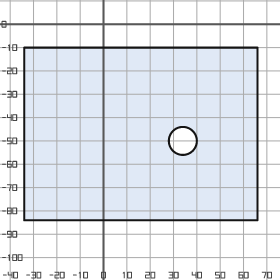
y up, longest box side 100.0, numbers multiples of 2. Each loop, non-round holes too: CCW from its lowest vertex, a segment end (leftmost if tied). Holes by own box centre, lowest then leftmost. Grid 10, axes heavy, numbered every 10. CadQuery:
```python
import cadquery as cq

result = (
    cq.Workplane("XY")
    .moveTo(-34.0, -84.0)
    .lineTo(66.0, -84.0)
    .lineTo(66.0, -10.0)
    .lineTo(-34.0, -10.0)
    .close()
    .moveTo(34.0, -50.0)
    .circle(6.0)
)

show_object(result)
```